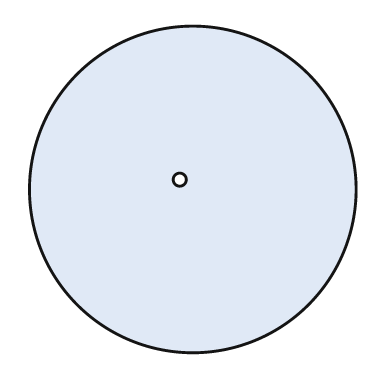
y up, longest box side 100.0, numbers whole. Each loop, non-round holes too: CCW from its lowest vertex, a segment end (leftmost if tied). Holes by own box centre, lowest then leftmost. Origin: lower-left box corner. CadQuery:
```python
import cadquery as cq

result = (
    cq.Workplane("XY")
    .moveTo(50.0, 50.0)
    .circle(50.0)
    .moveTo(46.0, 53.0)
    .circle(2.0)
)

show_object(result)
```